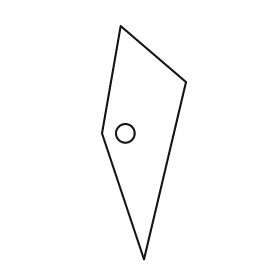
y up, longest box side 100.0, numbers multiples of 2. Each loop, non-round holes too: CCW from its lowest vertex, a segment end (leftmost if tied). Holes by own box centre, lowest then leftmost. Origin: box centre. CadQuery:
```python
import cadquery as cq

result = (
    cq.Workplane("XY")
    .moveTo(0.0, -50.0)
    .lineTo(18.0, 26.0)
    .lineTo(-10.0, 50.0)
    .lineTo(-18.0, 4.0)
    .close()
    .moveTo(-8.0, 4.0)
    .circle(4.0)
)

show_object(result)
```